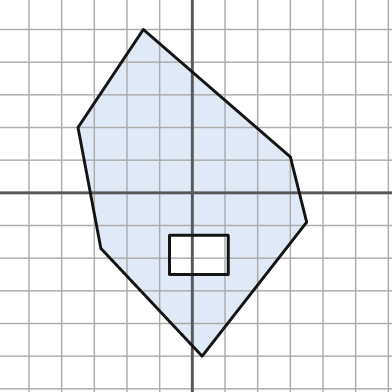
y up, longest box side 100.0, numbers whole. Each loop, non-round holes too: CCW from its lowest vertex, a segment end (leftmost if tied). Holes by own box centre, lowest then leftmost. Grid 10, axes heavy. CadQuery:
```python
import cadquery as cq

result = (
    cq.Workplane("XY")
    .moveTo(3.0, -50.0)
    .lineTo(35.0, -9.0)
    .lineTo(30.0, 11.0)
    .lineTo(-15.0, 50.0)
    .lineTo(-35.0, 20.0)
    .lineTo(-28.0, -17.0)
    .close()
    .moveTo(-7.0, -25.0)
    .lineTo(11.0, -25.0)
    .lineTo(11.0, -13.0)
    .lineTo(-7.0, -13.0)
    .close()
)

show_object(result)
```